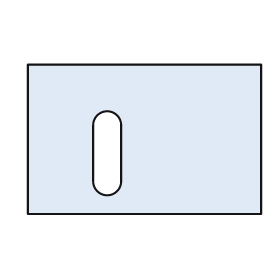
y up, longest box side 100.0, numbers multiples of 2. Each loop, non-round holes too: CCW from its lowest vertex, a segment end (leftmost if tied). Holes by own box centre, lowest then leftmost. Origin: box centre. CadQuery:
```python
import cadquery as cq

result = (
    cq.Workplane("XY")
    .moveTo(-50.0, -32.0)
    .lineTo(50.0, -32.0)
    .lineTo(50.0, 32.0)
    .lineTo(-50.0, 32.0)
    .close()
    .moveTo(-22.0, -18.0)
    .threePointArc((-16.0, -24.0), (-10.0, -18.0))
    .lineTo(-10.0, 6.0)
    .threePointArc((-16.0, 12.0), (-22.0, 6.0))
    .close()
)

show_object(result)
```